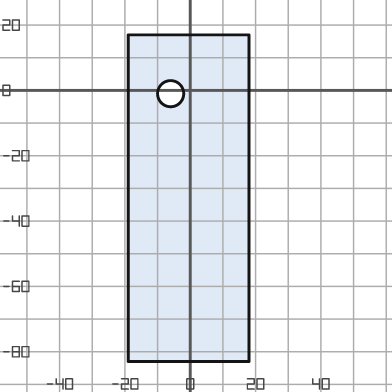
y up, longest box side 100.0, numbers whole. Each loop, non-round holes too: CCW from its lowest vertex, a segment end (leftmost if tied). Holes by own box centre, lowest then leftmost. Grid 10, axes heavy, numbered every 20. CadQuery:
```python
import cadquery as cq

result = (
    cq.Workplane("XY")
    .moveTo(-19.0, -83.0)
    .lineTo(18.0, -83.0)
    .lineTo(18.0, 17.0)
    .lineTo(-19.0, 17.0)
    .close()
    .moveTo(-6.0, -1.0)
    .circle(4.0)
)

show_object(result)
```